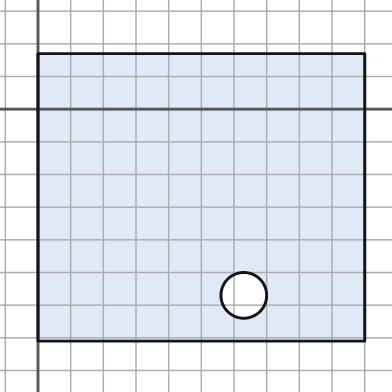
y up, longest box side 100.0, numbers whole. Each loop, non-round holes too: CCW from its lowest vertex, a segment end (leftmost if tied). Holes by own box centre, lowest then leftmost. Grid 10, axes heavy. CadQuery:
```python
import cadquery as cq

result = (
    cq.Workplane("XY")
    .moveTo(0.0, -71.0)
    .lineTo(100.0, -71.0)
    .lineTo(100.0, 17.0)
    .lineTo(0.0, 17.0)
    .close()
    .moveTo(63.0, -57.0)
    .circle(7.0)
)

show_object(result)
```